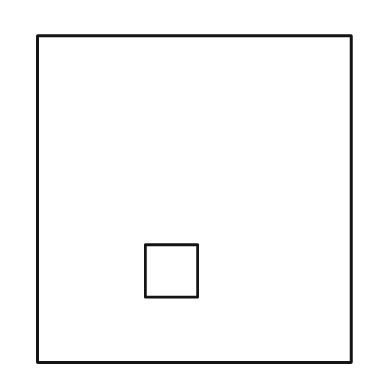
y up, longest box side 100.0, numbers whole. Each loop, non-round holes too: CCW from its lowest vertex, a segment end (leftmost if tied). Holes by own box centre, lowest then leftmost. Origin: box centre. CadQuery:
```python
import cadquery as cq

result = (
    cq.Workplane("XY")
    .moveTo(-48.0, -50.0)
    .lineTo(48.0, -50.0)
    .lineTo(48.0, 50.0)
    .lineTo(-48.0, 50.0)
    .close()
    .moveTo(-15.0, -30.0)
    .lineTo(1.0, -30.0)
    .lineTo(1.0, -14.0)
    .lineTo(-15.0, -14.0)
    .close()
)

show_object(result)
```